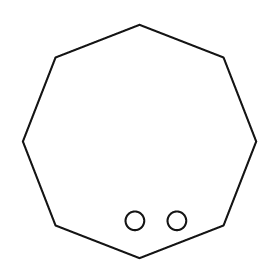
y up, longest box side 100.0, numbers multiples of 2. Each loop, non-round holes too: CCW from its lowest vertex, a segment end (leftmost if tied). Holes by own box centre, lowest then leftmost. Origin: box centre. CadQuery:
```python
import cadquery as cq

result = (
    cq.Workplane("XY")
    .moveTo(0.0, -50.0)
    .lineTo(36.0, -36.0)
    .lineTo(50.0, 0.0)
    .lineTo(36.0, 36.0)
    .lineTo(0.0, 50.0)
    .lineTo(-36.0, 36.0)
    .lineTo(-50.0, 0.0)
    .lineTo(-36.0, -36.0)
    .close()
    .moveTo(-2.0, -34.0)
    .circle(4.0)
    .moveTo(16.0, -34.0)
    .circle(4.0)
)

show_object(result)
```